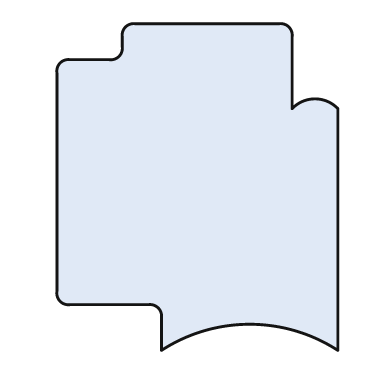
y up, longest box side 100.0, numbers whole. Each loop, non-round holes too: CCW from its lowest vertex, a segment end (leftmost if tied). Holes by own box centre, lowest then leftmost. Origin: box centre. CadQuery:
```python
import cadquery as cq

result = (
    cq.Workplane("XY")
    .moveTo(-11.0, -50.0)
    .threePointArc((16.0, -42.0), (43.0, -50.0))
    .lineTo(43.0, 24.0)
    .threePointArc((36.0, 27.0), (29.0, 24.0))
    .lineTo(29.0, 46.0)
    .threePointArc((28.0, 49.0), (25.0, 50.0))
    .lineTo(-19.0, 50.0)
    .threePointArc((-22.0, 49.0), (-23.0, 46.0))
    .lineTo(-23.0, 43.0)
    .threePointArc((-24.0, 40.0), (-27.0, 39.0))
    .lineTo(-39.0, 39.0)
    .threePointArc((-42.0, 38.0), (-43.0, 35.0))
    .lineTo(-43.0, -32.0)
    .threePointArc((-42.0, -35.0), (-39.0, -36.0))
    .lineTo(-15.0, -36.0)
    .threePointArc((-12.0, -37.0), (-11.0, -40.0))
    .close()
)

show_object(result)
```